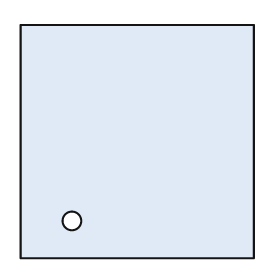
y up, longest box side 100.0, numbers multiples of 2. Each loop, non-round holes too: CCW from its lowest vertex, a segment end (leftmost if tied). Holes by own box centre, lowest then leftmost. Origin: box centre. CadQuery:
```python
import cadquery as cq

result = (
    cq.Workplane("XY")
    .moveTo(-50.0, -50.0)
    .lineTo(50.0, -50.0)
    .lineTo(50.0, 50.0)
    .lineTo(-50.0, 50.0)
    .close()
    .moveTo(-28.0, -34.0)
    .circle(4.0)
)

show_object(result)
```